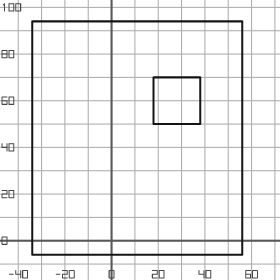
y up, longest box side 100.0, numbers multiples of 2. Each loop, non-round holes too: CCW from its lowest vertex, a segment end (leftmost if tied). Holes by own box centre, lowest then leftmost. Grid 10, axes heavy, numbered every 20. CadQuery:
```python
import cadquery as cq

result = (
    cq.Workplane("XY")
    .moveTo(-34.0, -6.0)
    .lineTo(56.0, -6.0)
    .lineTo(56.0, 94.0)
    .lineTo(-34.0, 94.0)
    .close()
    .moveTo(18.0, 50.0)
    .lineTo(38.0, 50.0)
    .lineTo(38.0, 70.0)
    .lineTo(18.0, 70.0)
    .close()
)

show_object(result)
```